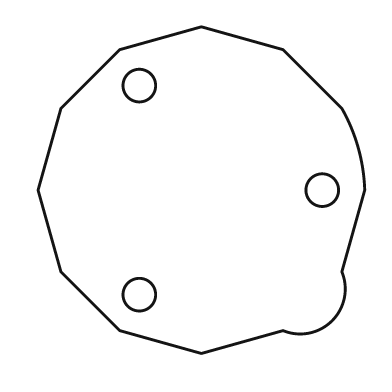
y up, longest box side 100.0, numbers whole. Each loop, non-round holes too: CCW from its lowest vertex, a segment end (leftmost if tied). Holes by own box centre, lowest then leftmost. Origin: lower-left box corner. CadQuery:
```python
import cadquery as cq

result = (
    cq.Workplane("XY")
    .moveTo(50.0, 0.0)
    .lineTo(75.0, 7.0)
    .threePointArc((90.0, 10.0), (93.0, 25.0))
    .lineTo(100.0, 50.0)
    .threePointArc((98.0, 63.0), (93.0, 75.0))
    .lineTo(75.0, 93.0)
    .lineTo(50.0, 100.0)
    .lineTo(25.0, 93.0)
    .lineTo(7.0, 75.0)
    .lineTo(0.0, 50.0)
    .lineTo(7.0, 25.0)
    .lineTo(25.0, 7.0)
    .close()
    .moveTo(31.0, 18.0)
    .circle(5.0)
    .moveTo(87.0, 50.0)
    .circle(5.0)
    .moveTo(31.0, 82.0)
    .circle(5.0)
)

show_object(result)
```